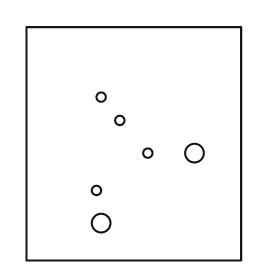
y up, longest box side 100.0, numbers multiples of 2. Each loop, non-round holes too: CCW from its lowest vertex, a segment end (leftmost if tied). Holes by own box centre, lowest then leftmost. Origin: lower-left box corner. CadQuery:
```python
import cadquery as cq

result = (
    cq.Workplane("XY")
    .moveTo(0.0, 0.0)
    .lineTo(92.0, 0.0)
    .lineTo(92.0, 100.0)
    .lineTo(0.0, 100.0)
    .close()
    .moveTo(32.0, 16.0)
    .circle(4.0)
    .moveTo(30.0, 30.0)
    .circle(2.0)
    .moveTo(52.0, 46.0)
    .circle(2.0)
    .moveTo(72.0, 46.0)
    .circle(4.0)
    .moveTo(40.0, 60.0)
    .circle(2.0)
    .moveTo(32.0, 70.0)
    .circle(2.0)
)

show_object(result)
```